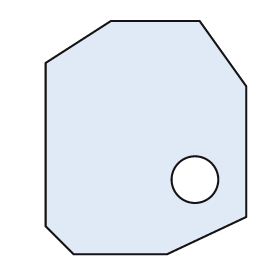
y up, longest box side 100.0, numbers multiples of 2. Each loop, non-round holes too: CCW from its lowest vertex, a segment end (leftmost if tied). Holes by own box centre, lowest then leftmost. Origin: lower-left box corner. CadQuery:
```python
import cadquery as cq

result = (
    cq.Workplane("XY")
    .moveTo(12.0, 0.0)
    .lineTo(52.0, 0.0)
    .lineTo(86.0, 16.0)
    .lineTo(86.0, 72.0)
    .lineTo(66.0, 100.0)
    .lineTo(28.0, 100.0)
    .lineTo(0.0, 82.0)
    .lineTo(0.0, 12.0)
    .close()
    .moveTo(64.0, 32.0)
    .circle(10.0)
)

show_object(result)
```